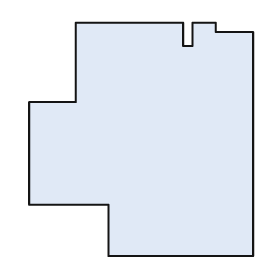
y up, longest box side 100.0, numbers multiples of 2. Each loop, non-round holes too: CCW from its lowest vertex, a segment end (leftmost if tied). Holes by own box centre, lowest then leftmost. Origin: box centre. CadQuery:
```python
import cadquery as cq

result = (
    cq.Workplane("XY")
    .moveTo(-14.0, -50.0)
    .lineTo(48.0, -50.0)
    .lineTo(48.0, 46.0)
    .lineTo(32.0, 46.0)
    .lineTo(32.0, 50.0)
    .lineTo(22.0, 50.0)
    .lineTo(22.0, 40.0)
    .lineTo(18.0, 40.0)
    .lineTo(18.0, 50.0)
    .lineTo(-28.0, 50.0)
    .lineTo(-28.0, 16.0)
    .lineTo(-48.0, 16.0)
    .lineTo(-48.0, -28.0)
    .lineTo(-14.0, -28.0)
    .close()
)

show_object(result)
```